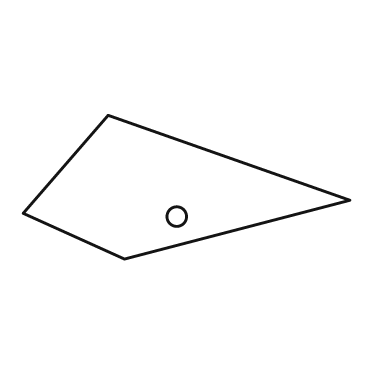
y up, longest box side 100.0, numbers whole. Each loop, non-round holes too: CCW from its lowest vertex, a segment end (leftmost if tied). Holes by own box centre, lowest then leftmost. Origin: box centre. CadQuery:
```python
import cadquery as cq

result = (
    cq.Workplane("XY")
    .moveTo(-19.0, -22.0)
    .lineTo(50.0, -4.0)
    .lineTo(-24.0, 22.0)
    .lineTo(-50.0, -8.0)
    .close()
    .moveTo(-3.0, -9.0)
    .circle(3.0)
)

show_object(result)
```